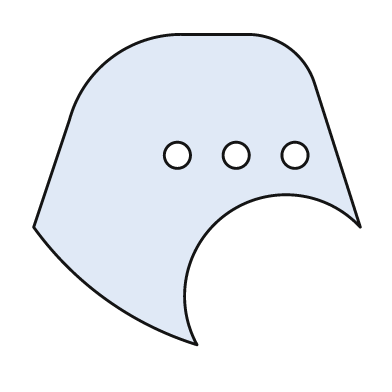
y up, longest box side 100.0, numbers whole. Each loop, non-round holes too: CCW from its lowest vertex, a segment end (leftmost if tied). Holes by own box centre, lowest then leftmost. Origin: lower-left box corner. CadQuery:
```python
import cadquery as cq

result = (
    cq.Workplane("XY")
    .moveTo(50.0, 0.0)
    .threePointArc((59.0, 40.0), (100.0, 36.0))
    .lineTo(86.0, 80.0)
    .threePointArc((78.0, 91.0), (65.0, 95.0))
    .lineTo(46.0, 95.0)
    .threePointArc((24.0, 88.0), (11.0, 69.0))
    .lineTo(0.0, 36.0)
    .threePointArc((22.0, 14.0), (50.0, 0.0))
    .close()
    .moveTo(44.0, 58.0)
    .circle(4.0)
    .moveTo(62.0, 58.0)
    .circle(4.0)
    .moveTo(80.0, 58.0)
    .circle(4.0)
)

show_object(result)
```